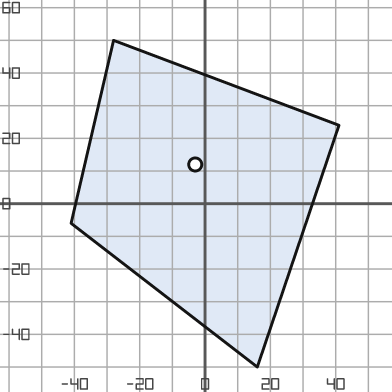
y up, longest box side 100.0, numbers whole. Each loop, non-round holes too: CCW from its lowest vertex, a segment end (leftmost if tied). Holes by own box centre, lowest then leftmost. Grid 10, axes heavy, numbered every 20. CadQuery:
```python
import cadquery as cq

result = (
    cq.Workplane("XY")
    .moveTo(16.0, -50.0)
    .lineTo(41.0, 24.0)
    .lineTo(-28.0, 50.0)
    .lineTo(-41.0, -6.0)
    .close()
    .moveTo(-3.0, 12.0)
    .circle(2.0)
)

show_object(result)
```